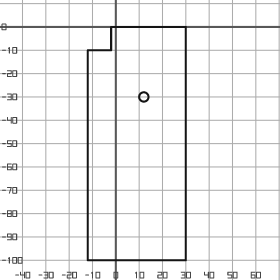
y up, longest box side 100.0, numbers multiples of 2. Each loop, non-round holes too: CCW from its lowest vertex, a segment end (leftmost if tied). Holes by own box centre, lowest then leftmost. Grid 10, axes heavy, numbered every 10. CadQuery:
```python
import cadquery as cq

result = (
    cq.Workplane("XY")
    .moveTo(-12.0, -100.0)
    .lineTo(30.0, -100.0)
    .lineTo(30.0, 0.0)
    .lineTo(-2.0, 0.0)
    .lineTo(-2.0, -10.0)
    .lineTo(-12.0, -10.0)
    .close()
    .moveTo(12.0, -30.0)
    .circle(2.0)
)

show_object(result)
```